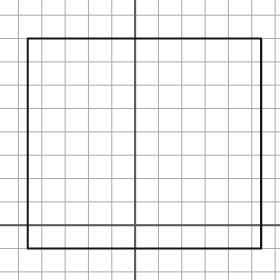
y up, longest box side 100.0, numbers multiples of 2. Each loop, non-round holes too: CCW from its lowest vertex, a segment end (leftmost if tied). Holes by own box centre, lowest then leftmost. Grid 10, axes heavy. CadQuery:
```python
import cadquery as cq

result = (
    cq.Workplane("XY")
    .moveTo(-46.0, -10.0)
    .lineTo(54.0, -10.0)
    .lineTo(54.0, 80.0)
    .lineTo(-46.0, 80.0)
    .close()
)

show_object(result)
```